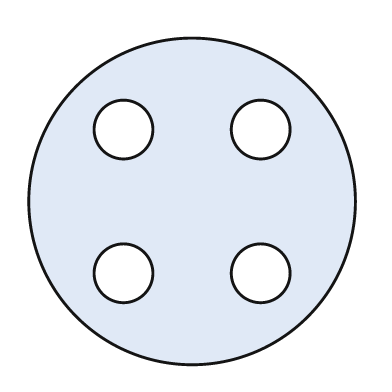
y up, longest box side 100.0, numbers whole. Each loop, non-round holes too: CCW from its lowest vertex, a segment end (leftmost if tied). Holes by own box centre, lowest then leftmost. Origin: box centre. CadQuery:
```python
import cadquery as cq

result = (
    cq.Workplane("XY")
    .moveTo(0.0, 0.0)
    .circle(50.0)
    .moveTo(-21.0, -22.0)
    .circle(9.0)
    .moveTo(21.0, -22.0)
    .circle(9.0)
    .moveTo(-21.0, 22.0)
    .circle(9.0)
    .moveTo(21.0, 22.0)
    .circle(9.0)
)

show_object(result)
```